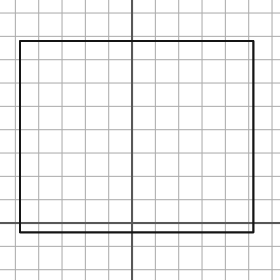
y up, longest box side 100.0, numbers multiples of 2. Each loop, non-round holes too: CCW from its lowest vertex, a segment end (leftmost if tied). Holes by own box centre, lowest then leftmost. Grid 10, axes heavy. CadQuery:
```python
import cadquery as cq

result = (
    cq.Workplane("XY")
    .moveTo(-48.0, -4.0)
    .lineTo(52.0, -4.0)
    .lineTo(52.0, 78.0)
    .lineTo(-48.0, 78.0)
    .close()
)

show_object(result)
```